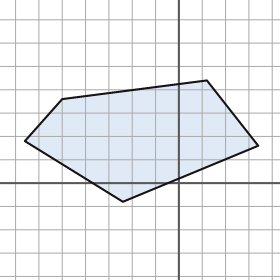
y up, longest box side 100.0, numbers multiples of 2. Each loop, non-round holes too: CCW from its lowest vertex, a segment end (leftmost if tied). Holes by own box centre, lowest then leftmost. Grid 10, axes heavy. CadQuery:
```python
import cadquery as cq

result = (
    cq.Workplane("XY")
    .moveTo(-24.0, -8.0)
    .lineTo(34.0, 16.0)
    .lineTo(12.0, 44.0)
    .lineTo(-50.0, 36.0)
    .lineTo(-66.0, 18.0)
    .close()
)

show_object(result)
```